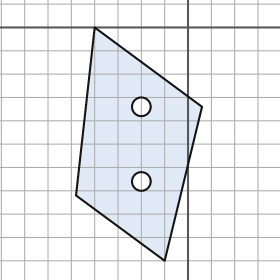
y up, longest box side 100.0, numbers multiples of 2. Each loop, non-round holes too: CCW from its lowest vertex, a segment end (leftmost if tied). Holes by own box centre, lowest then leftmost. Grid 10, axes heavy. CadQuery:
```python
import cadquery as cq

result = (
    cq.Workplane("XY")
    .moveTo(-10.0, -100.0)
    .lineTo(6.0, -34.0)
    .lineTo(-40.0, 0.0)
    .lineTo(-48.0, -72.0)
    .close()
    .moveTo(-20.0, -66.0)
    .circle(4.0)
    .moveTo(-20.0, -34.0)
    .circle(4.0)
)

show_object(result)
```